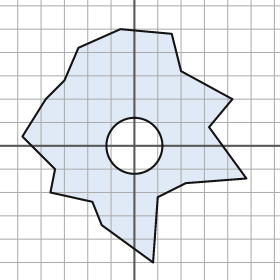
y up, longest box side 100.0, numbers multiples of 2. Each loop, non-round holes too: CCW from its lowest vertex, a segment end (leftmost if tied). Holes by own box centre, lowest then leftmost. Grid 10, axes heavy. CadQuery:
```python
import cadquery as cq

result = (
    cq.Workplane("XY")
    .moveTo(8.0, -50.0)
    .lineTo(10.0, -22.0)
    .lineTo(22.0, -16.0)
    .lineTo(48.0, -14.0)
    .lineTo(32.0, 8.0)
    .lineTo(42.0, 20.0)
    .lineTo(20.0, 32.0)
    .lineTo(16.0, 48.0)
    .lineTo(-6.0, 50.0)
    .lineTo(-24.0, 42.0)
    .lineTo(-30.0, 28.0)
    .lineTo(-38.0, 20.0)
    .lineTo(-48.0, 4.0)
    .lineTo(-34.0, -10.0)
    .lineTo(-36.0, -20.0)
    .lineTo(-18.0, -24.0)
    .lineTo(-14.0, -34.0)
    .close()
    .moveTo(0.0, 0.0)
    .circle(12.0)
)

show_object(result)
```